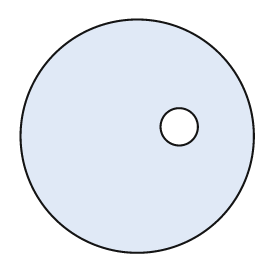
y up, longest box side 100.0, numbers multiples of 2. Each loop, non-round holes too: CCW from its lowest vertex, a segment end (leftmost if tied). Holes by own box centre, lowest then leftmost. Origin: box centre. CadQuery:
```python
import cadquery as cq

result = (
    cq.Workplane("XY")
    .moveTo(0.0, 0.0)
    .circle(50.0)
    .moveTo(18.0, 4.0)
    .circle(8.0)
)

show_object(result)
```